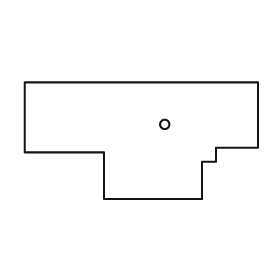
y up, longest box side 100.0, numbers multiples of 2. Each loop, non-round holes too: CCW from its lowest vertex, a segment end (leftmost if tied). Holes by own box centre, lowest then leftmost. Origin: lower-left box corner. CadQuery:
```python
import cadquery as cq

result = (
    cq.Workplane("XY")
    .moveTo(34.0, 0.0)
    .lineTo(76.0, 0.0)
    .lineTo(76.0, 16.0)
    .lineTo(82.0, 16.0)
    .lineTo(82.0, 22.0)
    .lineTo(100.0, 22.0)
    .lineTo(100.0, 50.0)
    .lineTo(0.0, 50.0)
    .lineTo(0.0, 20.0)
    .lineTo(34.0, 20.0)
    .close()
    .moveTo(60.0, 32.0)
    .circle(2.0)
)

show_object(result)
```